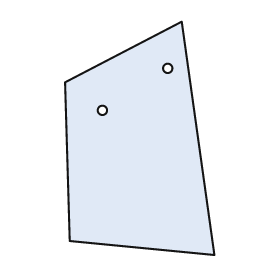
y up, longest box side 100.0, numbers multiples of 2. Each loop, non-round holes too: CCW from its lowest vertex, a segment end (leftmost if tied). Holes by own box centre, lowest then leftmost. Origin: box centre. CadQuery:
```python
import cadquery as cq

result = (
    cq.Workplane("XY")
    .moveTo(32.0, -50.0)
    .lineTo(18.0, 50.0)
    .lineTo(-32.0, 24.0)
    .lineTo(-30.0, -44.0)
    .close()
    .moveTo(-16.0, 12.0)
    .circle(2.0)
    .moveTo(12.0, 30.0)
    .circle(2.0)
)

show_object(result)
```